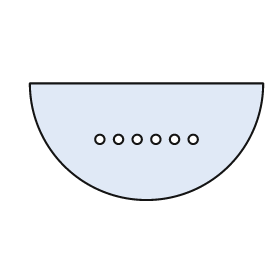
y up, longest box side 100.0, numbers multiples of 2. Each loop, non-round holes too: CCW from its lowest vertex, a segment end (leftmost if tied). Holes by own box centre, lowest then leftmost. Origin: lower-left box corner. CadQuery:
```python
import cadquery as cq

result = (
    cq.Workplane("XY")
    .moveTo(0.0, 50.0)
    .threePointArc((50.0, 0.0), (100.0, 50.0))
    .close()
    .moveTo(30.0, 26.0)
    .circle(2.0)
    .moveTo(38.0, 26.0)
    .circle(2.0)
    .moveTo(46.0, 26.0)
    .circle(2.0)
    .moveTo(54.0, 26.0)
    .circle(2.0)
    .moveTo(62.0, 26.0)
    .circle(2.0)
    .moveTo(70.0, 26.0)
    .circle(2.0)
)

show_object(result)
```